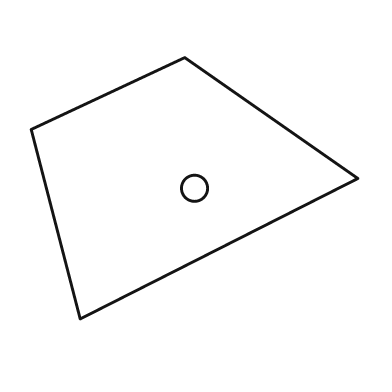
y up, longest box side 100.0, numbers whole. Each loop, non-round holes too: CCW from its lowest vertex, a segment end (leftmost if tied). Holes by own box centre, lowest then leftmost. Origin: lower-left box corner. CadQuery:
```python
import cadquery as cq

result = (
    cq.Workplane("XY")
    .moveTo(15.0, 0.0)
    .lineTo(100.0, 43.0)
    .lineTo(47.0, 80.0)
    .lineTo(0.0, 58.0)
    .close()
    .moveTo(50.0, 40.0)
    .circle(4.0)
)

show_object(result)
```